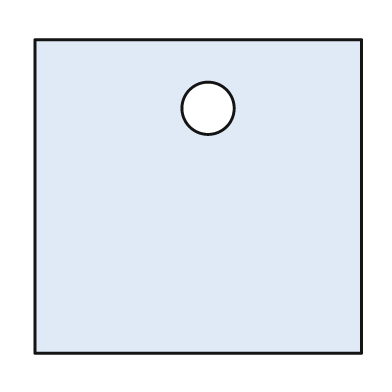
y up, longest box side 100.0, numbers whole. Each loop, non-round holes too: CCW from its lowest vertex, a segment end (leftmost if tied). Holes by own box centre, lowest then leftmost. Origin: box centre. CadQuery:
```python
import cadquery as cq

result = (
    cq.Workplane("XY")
    .moveTo(-50.0, -48.0)
    .lineTo(50.0, -48.0)
    .lineTo(50.0, 48.0)
    .lineTo(-50.0, 48.0)
    .close()
    .moveTo(3.0, 27.0)
    .circle(8.0)
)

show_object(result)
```